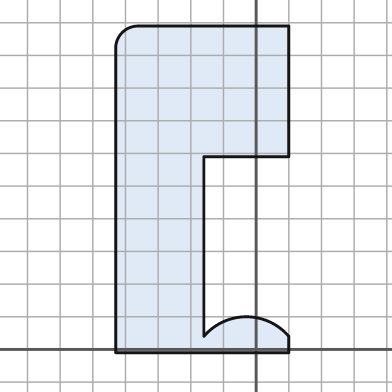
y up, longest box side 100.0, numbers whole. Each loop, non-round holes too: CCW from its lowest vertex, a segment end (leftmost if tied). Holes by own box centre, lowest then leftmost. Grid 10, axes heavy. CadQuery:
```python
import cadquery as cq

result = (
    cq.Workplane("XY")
    .moveTo(-43.0, -1.0)
    .lineTo(10.0, -1.0)
    .lineTo(10.0, 4.0)
    .threePointArc((-3.0, 10.0), (-16.0, 4.0))
    .lineTo(-16.0, 59.0)
    .lineTo(10.0, 59.0)
    .lineTo(10.0, 99.0)
    .lineTo(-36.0, 99.0)
    .threePointArc((-41.0, 97.0), (-43.0, 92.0))
    .close()
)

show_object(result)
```